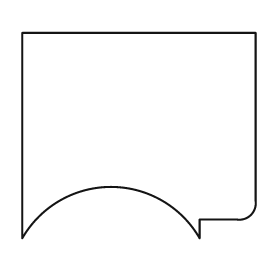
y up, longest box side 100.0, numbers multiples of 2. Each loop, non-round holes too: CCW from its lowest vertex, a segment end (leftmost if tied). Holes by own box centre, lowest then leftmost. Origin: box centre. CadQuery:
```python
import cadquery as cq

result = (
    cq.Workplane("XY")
    .moveTo(-50.0, -44.0)
    .threePointArc((-12.0, -22.0), (26.0, -44.0))
    .lineTo(26.0, -36.0)
    .lineTo(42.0, -36.0)
    .threePointArc((48.0, -34.0), (50.0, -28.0))
    .lineTo(50.0, 44.0)
    .lineTo(-50.0, 44.0)
    .close()
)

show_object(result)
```